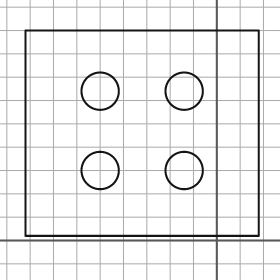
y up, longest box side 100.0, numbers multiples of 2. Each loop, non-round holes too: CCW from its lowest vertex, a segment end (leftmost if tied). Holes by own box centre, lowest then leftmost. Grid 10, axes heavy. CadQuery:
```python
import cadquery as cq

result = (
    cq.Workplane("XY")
    .moveTo(-82.0, 2.0)
    .lineTo(18.0, 2.0)
    .lineTo(18.0, 90.0)
    .lineTo(-82.0, 90.0)
    .close()
    .moveTo(-50.0, 30.0)
    .circle(8.0)
    .moveTo(-14.0, 30.0)
    .circle(8.0)
    .moveTo(-50.0, 64.0)
    .circle(8.0)
    .moveTo(-14.0, 64.0)
    .circle(8.0)
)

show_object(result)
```